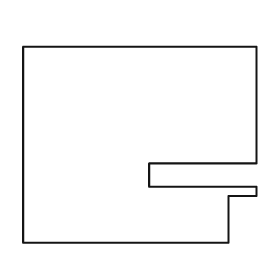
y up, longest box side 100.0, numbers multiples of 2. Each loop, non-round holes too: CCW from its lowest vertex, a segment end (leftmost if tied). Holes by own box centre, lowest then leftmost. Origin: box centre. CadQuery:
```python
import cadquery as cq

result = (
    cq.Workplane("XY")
    .moveTo(-50.0, -42.0)
    .lineTo(38.0, -42.0)
    .lineTo(38.0, -22.0)
    .lineTo(50.0, -22.0)
    .lineTo(50.0, -18.0)
    .lineTo(4.0, -18.0)
    .lineTo(4.0, -8.0)
    .lineTo(50.0, -8.0)
    .lineTo(50.0, 42.0)
    .lineTo(-50.0, 42.0)
    .close()
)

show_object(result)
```